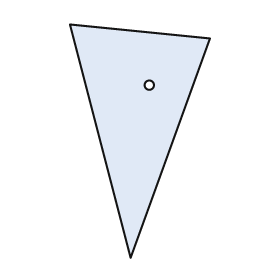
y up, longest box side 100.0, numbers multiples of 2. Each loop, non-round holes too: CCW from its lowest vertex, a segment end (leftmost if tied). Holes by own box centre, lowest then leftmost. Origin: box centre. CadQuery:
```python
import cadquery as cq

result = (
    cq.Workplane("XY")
    .moveTo(-4.0, -50.0)
    .lineTo(30.0, 44.0)
    .lineTo(-30.0, 50.0)
    .close()
    .moveTo(4.0, 24.0)
    .circle(2.0)
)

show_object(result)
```